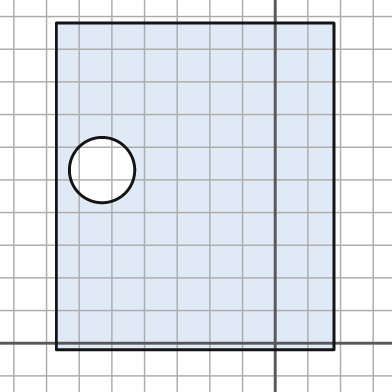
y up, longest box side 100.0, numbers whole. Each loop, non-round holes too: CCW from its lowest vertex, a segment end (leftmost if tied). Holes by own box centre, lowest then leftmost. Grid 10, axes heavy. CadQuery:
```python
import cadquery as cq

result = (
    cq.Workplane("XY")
    .moveTo(-67.0, -2.0)
    .lineTo(18.0, -2.0)
    .lineTo(18.0, 98.0)
    .lineTo(-67.0, 98.0)
    .close()
    .moveTo(-53.0, 53.0)
    .circle(10.0)
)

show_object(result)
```